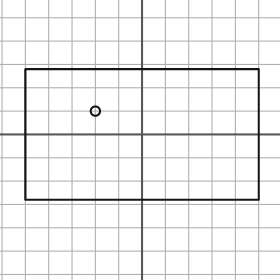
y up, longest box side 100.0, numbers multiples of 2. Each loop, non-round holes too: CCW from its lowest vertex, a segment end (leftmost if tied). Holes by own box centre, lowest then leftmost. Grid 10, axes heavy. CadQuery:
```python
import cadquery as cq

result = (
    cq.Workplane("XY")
    .moveTo(-50.0, -28.0)
    .lineTo(50.0, -28.0)
    .lineTo(50.0, 28.0)
    .lineTo(-50.0, 28.0)
    .close()
    .moveTo(-20.0, 10.0)
    .circle(2.0)
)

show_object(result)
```